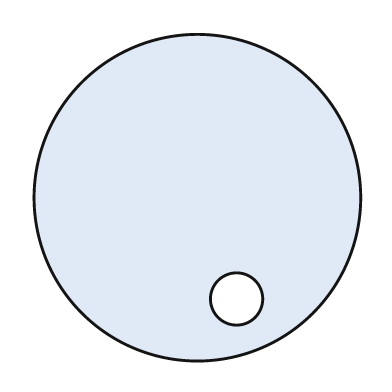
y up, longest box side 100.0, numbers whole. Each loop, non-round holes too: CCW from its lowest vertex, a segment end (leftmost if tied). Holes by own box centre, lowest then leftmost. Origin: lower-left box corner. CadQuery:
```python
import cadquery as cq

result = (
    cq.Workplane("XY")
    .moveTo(50.0, 50.0)
    .circle(50.0)
    .moveTo(62.0, 19.0)
    .circle(8.0)
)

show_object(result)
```